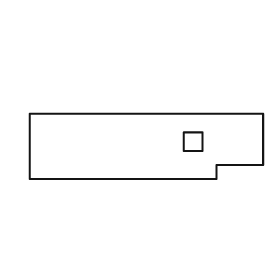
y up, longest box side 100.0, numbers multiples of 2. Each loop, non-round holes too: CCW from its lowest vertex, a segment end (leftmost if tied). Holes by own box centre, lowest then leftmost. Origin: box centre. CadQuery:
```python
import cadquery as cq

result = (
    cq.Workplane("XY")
    .moveTo(-50.0, -14.0)
    .lineTo(30.0, -14.0)
    .lineTo(30.0, -8.0)
    .lineTo(50.0, -8.0)
    .lineTo(50.0, 14.0)
    .lineTo(-50.0, 14.0)
    .close()
    .moveTo(16.0, -2.0)
    .lineTo(24.0, -2.0)
    .lineTo(24.0, 6.0)
    .lineTo(16.0, 6.0)
    .close()
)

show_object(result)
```